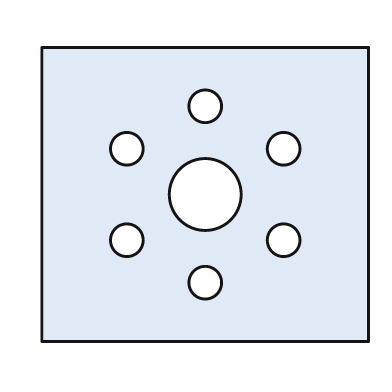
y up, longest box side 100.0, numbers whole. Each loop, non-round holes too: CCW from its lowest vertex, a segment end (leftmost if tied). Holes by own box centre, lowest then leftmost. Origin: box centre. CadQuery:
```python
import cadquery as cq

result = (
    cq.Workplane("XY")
    .moveTo(-50.0, -45.0)
    .lineTo(50.0, -45.0)
    .lineTo(50.0, 45.0)
    .lineTo(-50.0, 45.0)
    .close()
    .moveTo(0.0, -27.0)
    .circle(5.0)
    .moveTo(-24.0, -14.0)
    .circle(5.0)
    .moveTo(24.0, -14.0)
    .circle(5.0)
    .moveTo(0.0, 0.0)
    .circle(11.0)
    .moveTo(-24.0, 14.0)
    .circle(5.0)
    .moveTo(24.0, 14.0)
    .circle(5.0)
    .moveTo(0.0, 27.0)
    .circle(5.0)
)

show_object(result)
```